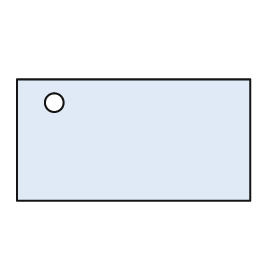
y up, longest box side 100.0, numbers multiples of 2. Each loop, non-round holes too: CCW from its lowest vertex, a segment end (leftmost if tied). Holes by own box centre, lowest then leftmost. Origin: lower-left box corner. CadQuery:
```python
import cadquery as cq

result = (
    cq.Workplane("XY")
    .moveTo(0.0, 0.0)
    .lineTo(100.0, 0.0)
    .lineTo(100.0, 52.0)
    .lineTo(0.0, 52.0)
    .close()
    .moveTo(16.0, 42.0)
    .circle(4.0)
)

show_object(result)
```